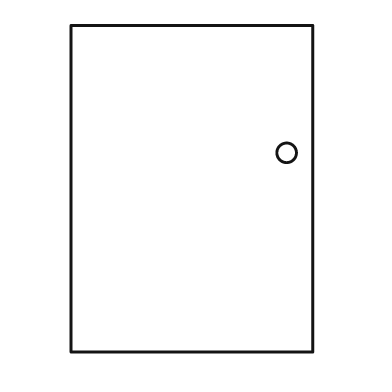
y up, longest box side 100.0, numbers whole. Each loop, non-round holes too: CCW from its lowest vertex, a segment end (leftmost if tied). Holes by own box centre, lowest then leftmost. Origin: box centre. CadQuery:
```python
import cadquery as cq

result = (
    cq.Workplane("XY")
    .moveTo(-37.0, -50.0)
    .lineTo(37.0, -50.0)
    .lineTo(37.0, 50.0)
    .lineTo(-37.0, 50.0)
    .close()
    .moveTo(29.0, 11.0)
    .circle(3.0)
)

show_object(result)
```